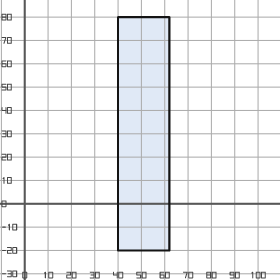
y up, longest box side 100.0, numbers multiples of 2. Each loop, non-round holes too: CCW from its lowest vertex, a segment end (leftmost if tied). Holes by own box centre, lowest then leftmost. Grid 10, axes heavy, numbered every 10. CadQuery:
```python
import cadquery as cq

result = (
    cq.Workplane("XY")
    .moveTo(40.0, -20.0)
    .lineTo(62.0, -20.0)
    .lineTo(62.0, 80.0)
    .lineTo(40.0, 80.0)
    .close()
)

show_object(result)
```